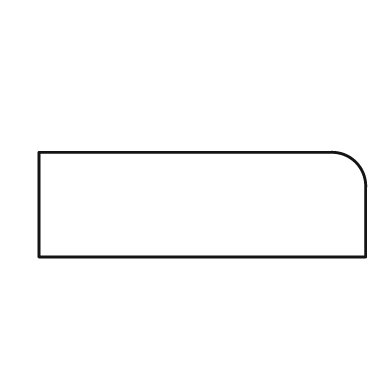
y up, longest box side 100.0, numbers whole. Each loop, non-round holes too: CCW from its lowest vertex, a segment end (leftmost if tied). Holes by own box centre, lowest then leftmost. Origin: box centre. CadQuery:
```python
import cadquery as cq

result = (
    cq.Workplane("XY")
    .moveTo(-50.0, -16.0)
    .lineTo(50.0, -16.0)
    .lineTo(50.0, 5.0)
    .threePointArc((47.0, 13.0), (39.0, 16.0))
    .lineTo(-50.0, 16.0)
    .close()
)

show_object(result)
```